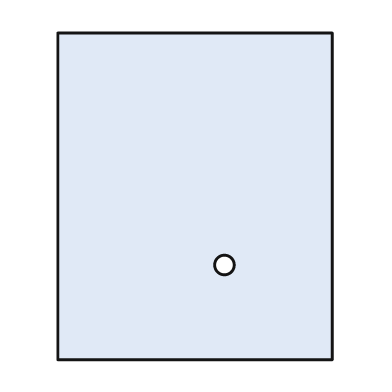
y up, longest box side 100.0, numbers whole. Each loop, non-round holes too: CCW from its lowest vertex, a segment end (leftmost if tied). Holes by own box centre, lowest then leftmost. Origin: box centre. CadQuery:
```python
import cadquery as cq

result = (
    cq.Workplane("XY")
    .moveTo(-42.0, -50.0)
    .lineTo(42.0, -50.0)
    .lineTo(42.0, 50.0)
    .lineTo(-42.0, 50.0)
    .close()
    .moveTo(9.0, -21.0)
    .circle(3.0)
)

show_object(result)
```